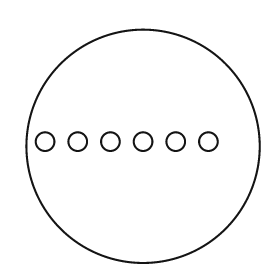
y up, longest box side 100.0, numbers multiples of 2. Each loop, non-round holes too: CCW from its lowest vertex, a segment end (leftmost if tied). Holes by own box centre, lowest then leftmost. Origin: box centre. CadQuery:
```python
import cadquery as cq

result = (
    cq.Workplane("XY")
    .moveTo(0.0, 0.0)
    .circle(50.0)
    .moveTo(-42.0, 2.0)
    .circle(4.0)
    .moveTo(-28.0, 2.0)
    .circle(4.0)
    .moveTo(-14.0, 2.0)
    .circle(4.0)
    .moveTo(0.0, 2.0)
    .circle(4.0)
    .moveTo(14.0, 2.0)
    .circle(4.0)
    .moveTo(28.0, 2.0)
    .circle(4.0)
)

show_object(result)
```